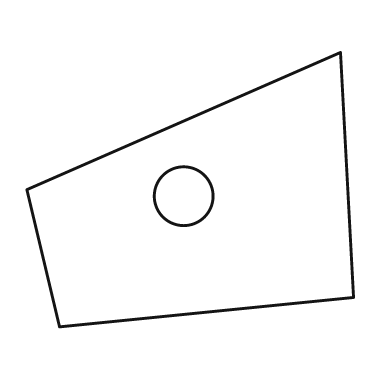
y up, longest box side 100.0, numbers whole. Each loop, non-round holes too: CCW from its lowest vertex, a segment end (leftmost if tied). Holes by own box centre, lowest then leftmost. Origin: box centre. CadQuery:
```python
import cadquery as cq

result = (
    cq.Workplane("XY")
    .moveTo(-40.0, -42.0)
    .lineTo(50.0, -33.0)
    .lineTo(46.0, 42.0)
    .lineTo(-50.0, 0.0)
    .close()
    .moveTo(-2.0, -2.0)
    .circle(9.0)
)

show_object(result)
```